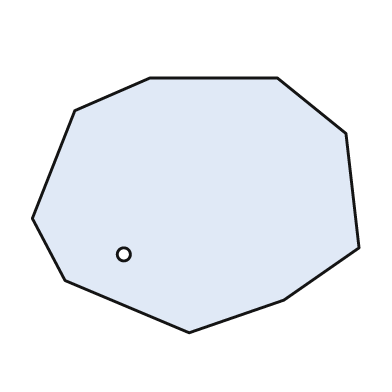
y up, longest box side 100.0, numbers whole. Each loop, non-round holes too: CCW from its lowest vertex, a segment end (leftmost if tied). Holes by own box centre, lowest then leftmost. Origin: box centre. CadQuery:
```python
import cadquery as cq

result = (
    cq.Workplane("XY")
    .moveTo(-2.0, -39.0)
    .lineTo(27.0, -29.0)
    .lineTo(50.0, -13.0)
    .lineTo(46.0, 22.0)
    .lineTo(25.0, 39.0)
    .lineTo(-14.0, 39.0)
    .lineTo(-37.0, 29.0)
    .lineTo(-50.0, -4.0)
    .lineTo(-40.0, -23.0)
    .close()
    .moveTo(-22.0, -15.0)
    .circle(2.0)
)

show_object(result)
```